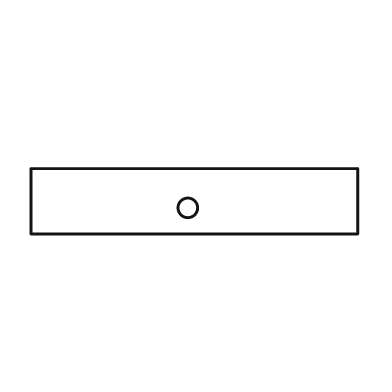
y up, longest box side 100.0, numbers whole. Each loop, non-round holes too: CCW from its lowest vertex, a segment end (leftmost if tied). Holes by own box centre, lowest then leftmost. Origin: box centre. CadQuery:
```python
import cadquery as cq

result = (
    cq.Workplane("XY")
    .moveTo(-50.0, -10.0)
    .lineTo(50.0, -10.0)
    .lineTo(50.0, 10.0)
    .lineTo(-50.0, 10.0)
    .close()
    .moveTo(-2.0, -2.0)
    .circle(3.0)
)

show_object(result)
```